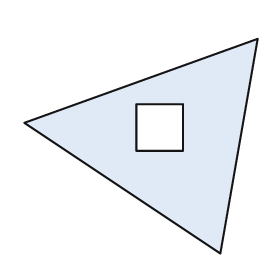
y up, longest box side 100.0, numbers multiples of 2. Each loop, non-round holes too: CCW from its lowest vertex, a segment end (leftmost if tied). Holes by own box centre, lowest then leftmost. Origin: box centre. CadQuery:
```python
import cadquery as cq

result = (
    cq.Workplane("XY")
    .moveTo(34.0, -46.0)
    .lineTo(50.0, 46.0)
    .lineTo(-50.0, 10.0)
    .close()
    .moveTo(-2.0, -2.0)
    .lineTo(18.0, -2.0)
    .lineTo(18.0, 18.0)
    .lineTo(-2.0, 18.0)
    .close()
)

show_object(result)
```